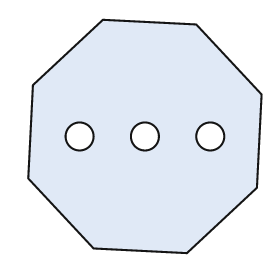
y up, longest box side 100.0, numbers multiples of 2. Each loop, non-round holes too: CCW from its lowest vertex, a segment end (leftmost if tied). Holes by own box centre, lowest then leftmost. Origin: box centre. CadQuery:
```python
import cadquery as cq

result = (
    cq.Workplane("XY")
    .moveTo(18.0, -50.0)
    .lineTo(48.0, -22.0)
    .lineTo(50.0, 18.0)
    .lineTo(22.0, 48.0)
    .lineTo(-18.0, 50.0)
    .lineTo(-48.0, 22.0)
    .lineTo(-50.0, -18.0)
    .lineTo(-22.0, -48.0)
    .close()
    .moveTo(-28.0, 0.0)
    .circle(6.0)
    .moveTo(0.0, 0.0)
    .circle(6.0)
    .moveTo(28.0, 0.0)
    .circle(6.0)
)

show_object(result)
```